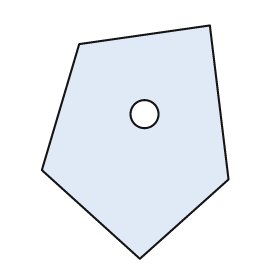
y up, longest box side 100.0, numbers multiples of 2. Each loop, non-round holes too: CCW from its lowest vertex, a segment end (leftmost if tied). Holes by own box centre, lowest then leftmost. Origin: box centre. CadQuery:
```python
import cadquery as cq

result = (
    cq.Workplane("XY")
    .moveTo(2.0, -50.0)
    .lineTo(40.0, -16.0)
    .lineTo(32.0, 50.0)
    .lineTo(-24.0, 42.0)
    .lineTo(-40.0, -12.0)
    .close()
    .moveTo(4.0, 12.0)
    .circle(6.0)
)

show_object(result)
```